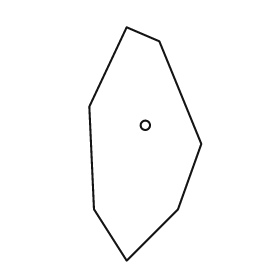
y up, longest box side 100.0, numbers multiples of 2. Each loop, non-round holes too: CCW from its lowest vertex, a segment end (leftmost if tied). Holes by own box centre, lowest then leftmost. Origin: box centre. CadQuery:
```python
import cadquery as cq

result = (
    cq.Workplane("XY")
    .moveTo(-8.0, -50.0)
    .lineTo(14.0, -28.0)
    .lineTo(24.0, 0.0)
    .lineTo(6.0, 44.0)
    .lineTo(-8.0, 50.0)
    .lineTo(-24.0, 16.0)
    .lineTo(-22.0, -28.0)
    .close()
    .moveTo(0.0, 8.0)
    .circle(2.0)
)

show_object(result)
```